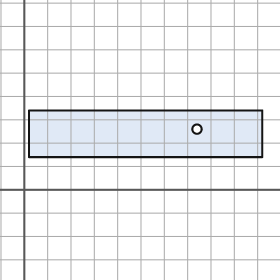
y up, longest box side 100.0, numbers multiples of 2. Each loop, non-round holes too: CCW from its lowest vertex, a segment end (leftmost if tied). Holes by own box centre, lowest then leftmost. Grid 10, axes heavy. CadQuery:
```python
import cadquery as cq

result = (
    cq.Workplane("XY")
    .moveTo(2.0, 14.0)
    .lineTo(102.0, 14.0)
    .lineTo(102.0, 34.0)
    .lineTo(2.0, 34.0)
    .close()
    .moveTo(74.0, 26.0)
    .circle(2.0)
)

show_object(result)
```